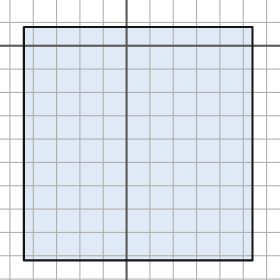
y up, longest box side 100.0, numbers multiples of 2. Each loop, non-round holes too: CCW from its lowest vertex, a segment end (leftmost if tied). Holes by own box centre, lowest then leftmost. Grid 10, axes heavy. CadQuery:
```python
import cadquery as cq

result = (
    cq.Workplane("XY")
    .moveTo(-44.0, -92.0)
    .lineTo(54.0, -92.0)
    .lineTo(54.0, 8.0)
    .lineTo(-44.0, 8.0)
    .close()
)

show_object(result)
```